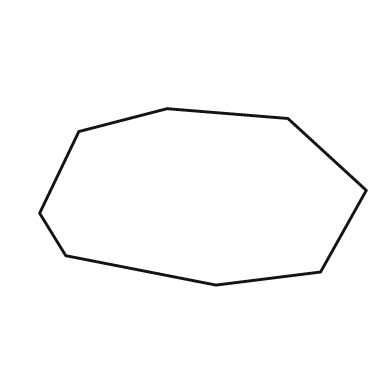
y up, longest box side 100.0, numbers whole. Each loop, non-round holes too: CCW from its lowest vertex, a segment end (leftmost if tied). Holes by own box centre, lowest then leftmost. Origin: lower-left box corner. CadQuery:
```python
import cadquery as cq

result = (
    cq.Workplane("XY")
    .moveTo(54.0, 0.0)
    .lineTo(86.0, 4.0)
    .lineTo(100.0, 29.0)
    .lineTo(76.0, 51.0)
    .lineTo(39.0, 54.0)
    .lineTo(12.0, 47.0)
    .lineTo(0.0, 22.0)
    .lineTo(8.0, 9.0)
    .close()
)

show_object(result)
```